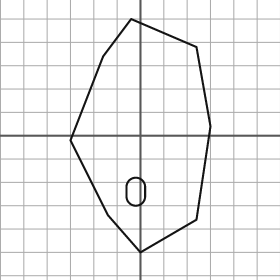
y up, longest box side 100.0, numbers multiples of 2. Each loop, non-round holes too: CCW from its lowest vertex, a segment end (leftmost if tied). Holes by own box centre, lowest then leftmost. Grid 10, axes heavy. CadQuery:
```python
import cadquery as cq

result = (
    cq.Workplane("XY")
    .moveTo(0.0, -50.0)
    .lineTo(24.0, -36.0)
    .lineTo(30.0, 4.0)
    .lineTo(24.0, 38.0)
    .lineTo(-4.0, 50.0)
    .lineTo(-16.0, 34.0)
    .lineTo(-30.0, -2.0)
    .lineTo(-14.0, -34.0)
    .close()
    .moveTo(-6.0, -26.0)
    .threePointArc((-2.0, -30.0), (2.0, -26.0))
    .lineTo(2.0, -22.0)
    .threePointArc((-2.0, -18.0), (-6.0, -22.0))
    .close()
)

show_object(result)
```